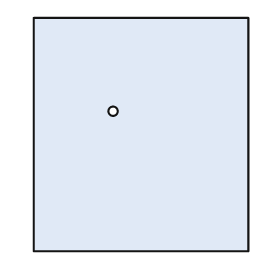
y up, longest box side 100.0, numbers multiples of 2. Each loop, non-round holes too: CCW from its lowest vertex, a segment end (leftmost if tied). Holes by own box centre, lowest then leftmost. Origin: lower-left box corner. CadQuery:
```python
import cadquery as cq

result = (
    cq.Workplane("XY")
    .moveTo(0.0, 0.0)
    .lineTo(92.0, 0.0)
    .lineTo(92.0, 100.0)
    .lineTo(0.0, 100.0)
    .close()
    .moveTo(34.0, 60.0)
    .circle(2.0)
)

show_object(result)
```